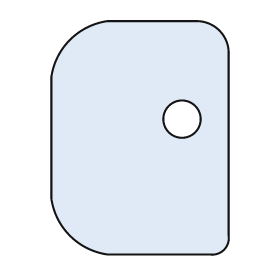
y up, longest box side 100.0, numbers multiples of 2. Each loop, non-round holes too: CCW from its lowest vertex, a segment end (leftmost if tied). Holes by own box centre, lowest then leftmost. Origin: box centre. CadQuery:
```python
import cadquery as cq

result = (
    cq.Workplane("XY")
    .moveTo(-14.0, -50.0)
    .lineTo(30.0, -50.0)
    .threePointArc((36.0, -48.0), (38.0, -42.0))
    .lineTo(38.0, 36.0)
    .threePointArc((34.0, 46.0), (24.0, 50.0))
    .lineTo(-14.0, 50.0)
    .threePointArc((-30.0, 42.0), (-38.0, 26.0))
    .lineTo(-38.0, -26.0)
    .threePointArc((-30.0, -42.0), (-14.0, -50.0))
    .close()
    .moveTo(18.0, 8.0)
    .circle(8.0)
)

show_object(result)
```